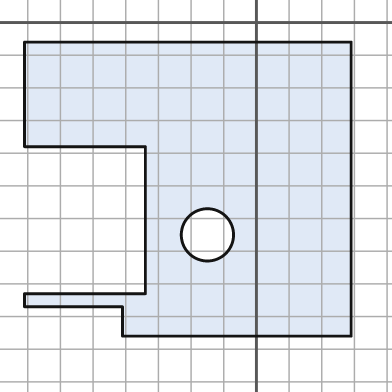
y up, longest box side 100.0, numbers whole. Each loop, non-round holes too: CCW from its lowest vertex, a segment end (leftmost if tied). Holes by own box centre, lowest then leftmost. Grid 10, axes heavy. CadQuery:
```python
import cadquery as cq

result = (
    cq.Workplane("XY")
    .moveTo(-41.0, -96.0)
    .lineTo(29.0, -96.0)
    .lineTo(29.0, -6.0)
    .lineTo(-71.0, -6.0)
    .lineTo(-71.0, -38.0)
    .lineTo(-34.0, -38.0)
    .lineTo(-34.0, -83.0)
    .lineTo(-71.0, -83.0)
    .lineTo(-71.0, -87.0)
    .lineTo(-41.0, -87.0)
    .close()
    .moveTo(-15.0, -65.0)
    .circle(8.0)
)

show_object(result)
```